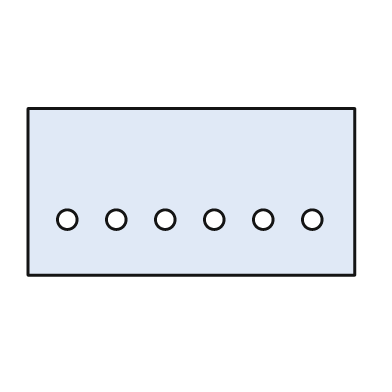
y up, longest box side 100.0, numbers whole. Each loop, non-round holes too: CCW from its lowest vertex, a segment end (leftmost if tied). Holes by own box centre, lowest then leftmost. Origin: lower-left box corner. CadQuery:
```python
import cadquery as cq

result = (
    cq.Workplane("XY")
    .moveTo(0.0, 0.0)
    .lineTo(100.0, 0.0)
    .lineTo(100.0, 51.0)
    .lineTo(0.0, 51.0)
    .close()
    .moveTo(12.0, 17.0)
    .circle(3.0)
    .moveTo(27.0, 17.0)
    .circle(3.0)
    .moveTo(42.0, 17.0)
    .circle(3.0)
    .moveTo(57.0, 17.0)
    .circle(3.0)
    .moveTo(72.0, 17.0)
    .circle(3.0)
    .moveTo(87.0, 17.0)
    .circle(3.0)
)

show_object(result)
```